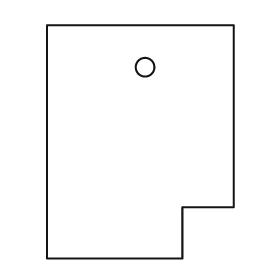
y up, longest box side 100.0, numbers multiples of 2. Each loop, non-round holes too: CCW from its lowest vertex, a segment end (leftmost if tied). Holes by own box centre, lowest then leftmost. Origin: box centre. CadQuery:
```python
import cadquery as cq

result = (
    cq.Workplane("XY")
    .moveTo(-40.0, -50.0)
    .lineTo(18.0, -50.0)
    .lineTo(18.0, -28.0)
    .lineTo(40.0, -28.0)
    .lineTo(40.0, 50.0)
    .lineTo(-40.0, 50.0)
    .close()
    .moveTo(2.0, 32.0)
    .circle(4.0)
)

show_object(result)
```